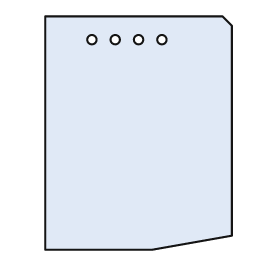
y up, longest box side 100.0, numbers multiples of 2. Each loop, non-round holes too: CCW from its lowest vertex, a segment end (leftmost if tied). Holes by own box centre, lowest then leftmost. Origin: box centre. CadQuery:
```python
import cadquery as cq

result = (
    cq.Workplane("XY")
    .moveTo(-40.0, -50.0)
    .lineTo(6.0, -50.0)
    .lineTo(40.0, -44.0)
    .lineTo(40.0, 46.0)
    .lineTo(36.0, 50.0)
    .lineTo(-40.0, 50.0)
    .close()
    .moveTo(-20.0, 40.0)
    .circle(2.0)
    .moveTo(-10.0, 40.0)
    .circle(2.0)
    .moveTo(0.0, 40.0)
    .circle(2.0)
    .moveTo(10.0, 40.0)
    .circle(2.0)
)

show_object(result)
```